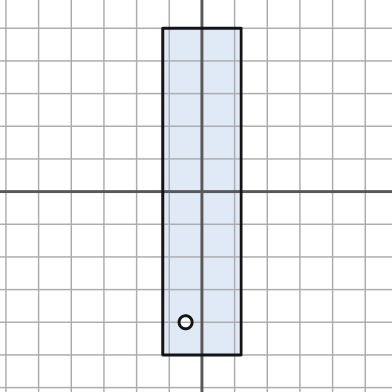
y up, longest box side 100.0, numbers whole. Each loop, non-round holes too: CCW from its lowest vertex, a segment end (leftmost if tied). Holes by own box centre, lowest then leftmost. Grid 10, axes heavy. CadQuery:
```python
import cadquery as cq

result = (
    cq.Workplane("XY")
    .moveTo(-12.0, -50.0)
    .lineTo(12.0, -50.0)
    .lineTo(12.0, 50.0)
    .lineTo(-12.0, 50.0)
    .close()
    .moveTo(-5.0, -40.0)
    .circle(2.0)
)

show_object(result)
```